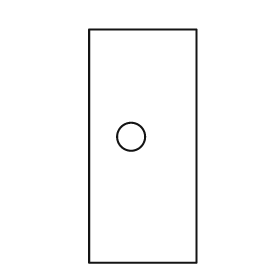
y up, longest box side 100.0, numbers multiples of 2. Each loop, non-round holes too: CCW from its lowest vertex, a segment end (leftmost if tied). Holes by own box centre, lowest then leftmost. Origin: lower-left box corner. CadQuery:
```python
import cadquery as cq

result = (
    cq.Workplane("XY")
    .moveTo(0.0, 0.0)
    .lineTo(46.0, 0.0)
    .lineTo(46.0, 100.0)
    .lineTo(0.0, 100.0)
    .close()
    .moveTo(18.0, 54.0)
    .circle(6.0)
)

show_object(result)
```